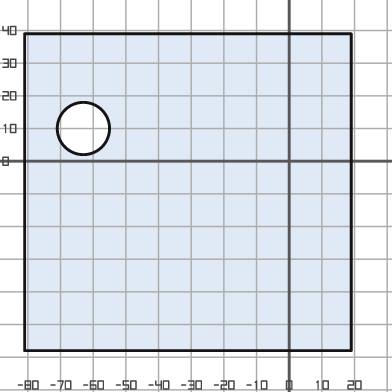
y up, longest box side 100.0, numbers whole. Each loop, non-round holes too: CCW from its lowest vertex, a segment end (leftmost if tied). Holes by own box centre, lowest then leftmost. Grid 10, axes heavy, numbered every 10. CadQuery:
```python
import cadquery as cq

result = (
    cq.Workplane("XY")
    .moveTo(-81.0, -58.0)
    .lineTo(19.0, -58.0)
    .lineTo(19.0, 39.0)
    .lineTo(-81.0, 39.0)
    .close()
    .moveTo(-63.0, 10.0)
    .circle(8.0)
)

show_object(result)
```